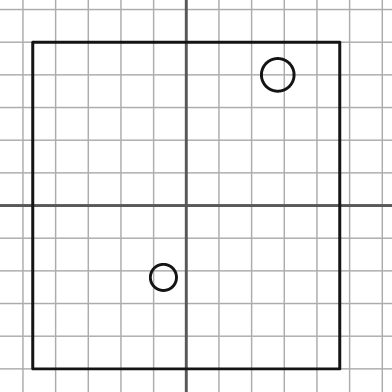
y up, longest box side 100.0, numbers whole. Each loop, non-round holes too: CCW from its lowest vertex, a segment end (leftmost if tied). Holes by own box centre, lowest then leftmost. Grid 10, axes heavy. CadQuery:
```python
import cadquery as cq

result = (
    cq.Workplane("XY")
    .moveTo(-47.0, -50.0)
    .lineTo(47.0, -50.0)
    .lineTo(47.0, 50.0)
    .lineTo(-47.0, 50.0)
    .close()
    .moveTo(-7.0, -22.0)
    .circle(4.0)
    .moveTo(28.0, 40.0)
    .circle(5.0)
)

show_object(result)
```